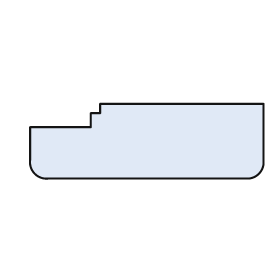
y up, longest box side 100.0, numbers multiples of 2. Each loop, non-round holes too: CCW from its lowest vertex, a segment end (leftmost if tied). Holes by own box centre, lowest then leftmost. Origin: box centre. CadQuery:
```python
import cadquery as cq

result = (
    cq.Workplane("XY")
    .moveTo(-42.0, -16.0)
    .lineTo(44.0, -16.0)
    .threePointArc((48.0, -14.0), (50.0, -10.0))
    .lineTo(50.0, 16.0)
    .lineTo(-20.0, 16.0)
    .lineTo(-20.0, 12.0)
    .lineTo(-24.0, 12.0)
    .lineTo(-24.0, 6.0)
    .lineTo(-50.0, 6.0)
    .lineTo(-50.0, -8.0)
    .threePointArc((-48.0, -14.0), (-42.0, -16.0))
    .close()
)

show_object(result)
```